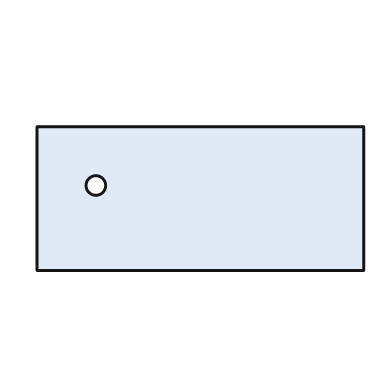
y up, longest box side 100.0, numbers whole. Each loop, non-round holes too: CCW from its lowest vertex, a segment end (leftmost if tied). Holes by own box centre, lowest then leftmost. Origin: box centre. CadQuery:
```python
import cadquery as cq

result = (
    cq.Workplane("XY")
    .moveTo(-50.0, -22.0)
    .lineTo(50.0, -22.0)
    .lineTo(50.0, 22.0)
    .lineTo(-50.0, 22.0)
    .close()
    .moveTo(-32.0, 4.0)
    .circle(3.0)
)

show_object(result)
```